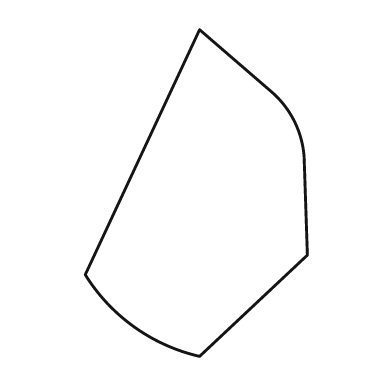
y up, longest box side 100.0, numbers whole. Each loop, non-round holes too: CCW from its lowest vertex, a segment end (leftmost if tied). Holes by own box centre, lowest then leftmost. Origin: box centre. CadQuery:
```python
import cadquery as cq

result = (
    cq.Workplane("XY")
    .moveTo(1.0, -50.0)
    .lineTo(34.0, -19.0)
    .lineTo(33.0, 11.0)
    .threePointArc((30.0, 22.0), (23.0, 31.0))
    .lineTo(1.0, 50.0)
    .lineTo(-34.0, -25.0)
    .threePointArc((-19.0, -41.0), (1.0, -50.0))
    .close()
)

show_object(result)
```